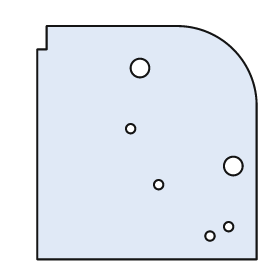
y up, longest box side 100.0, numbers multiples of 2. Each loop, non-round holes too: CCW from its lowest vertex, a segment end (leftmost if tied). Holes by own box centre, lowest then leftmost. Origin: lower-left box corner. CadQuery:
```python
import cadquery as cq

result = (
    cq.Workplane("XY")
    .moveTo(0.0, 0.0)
    .lineTo(94.0, 0.0)
    .lineTo(94.0, 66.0)
    .threePointArc((84.0, 90.0), (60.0, 100.0))
    .lineTo(4.0, 100.0)
    .lineTo(4.0, 90.0)
    .lineTo(0.0, 90.0)
    .close()
    .moveTo(74.0, 10.0)
    .circle(2.0)
    .moveTo(82.0, 14.0)
    .circle(2.0)
    .moveTo(52.0, 32.0)
    .circle(2.0)
    .moveTo(84.0, 40.0)
    .circle(4.0)
    .moveTo(40.0, 56.0)
    .circle(2.0)
    .moveTo(44.0, 82.0)
    .circle(4.0)
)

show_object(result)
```